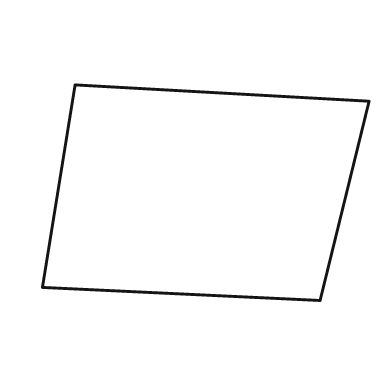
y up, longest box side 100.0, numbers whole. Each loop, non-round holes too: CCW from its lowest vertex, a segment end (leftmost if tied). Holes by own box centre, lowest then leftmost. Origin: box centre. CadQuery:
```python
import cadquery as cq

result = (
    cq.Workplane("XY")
    .moveTo(35.0, -33.0)
    .lineTo(50.0, 28.0)
    .lineTo(-40.0, 33.0)
    .lineTo(-50.0, -29.0)
    .close()
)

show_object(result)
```